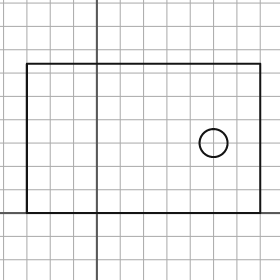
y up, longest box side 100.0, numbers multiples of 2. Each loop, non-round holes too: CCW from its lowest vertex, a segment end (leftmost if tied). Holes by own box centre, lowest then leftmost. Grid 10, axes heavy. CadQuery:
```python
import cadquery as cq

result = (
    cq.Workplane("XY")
    .moveTo(-30.0, 0.0)
    .lineTo(70.0, 0.0)
    .lineTo(70.0, 64.0)
    .lineTo(-30.0, 64.0)
    .close()
    .moveTo(50.0, 30.0)
    .circle(6.0)
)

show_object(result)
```